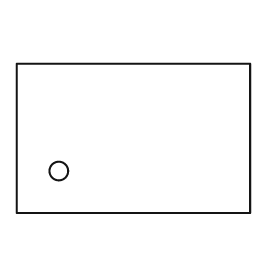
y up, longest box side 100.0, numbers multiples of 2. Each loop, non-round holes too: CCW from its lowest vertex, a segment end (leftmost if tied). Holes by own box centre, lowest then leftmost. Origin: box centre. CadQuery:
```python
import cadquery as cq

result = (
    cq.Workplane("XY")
    .moveTo(-50.0, -32.0)
    .lineTo(50.0, -32.0)
    .lineTo(50.0, 32.0)
    .lineTo(-50.0, 32.0)
    .close()
    .moveTo(-32.0, -14.0)
    .circle(4.0)
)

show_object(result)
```